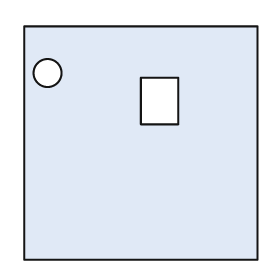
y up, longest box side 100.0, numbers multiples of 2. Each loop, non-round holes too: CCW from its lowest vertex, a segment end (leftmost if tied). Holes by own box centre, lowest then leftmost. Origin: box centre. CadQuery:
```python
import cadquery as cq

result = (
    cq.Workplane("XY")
    .moveTo(-50.0, -50.0)
    .lineTo(50.0, -50.0)
    .lineTo(50.0, 50.0)
    .lineTo(-50.0, 50.0)
    .close()
    .moveTo(0.0, 8.0)
    .lineTo(16.0, 8.0)
    .lineTo(16.0, 28.0)
    .lineTo(0.0, 28.0)
    .close()
    .moveTo(-40.0, 30.0)
    .circle(6.0)
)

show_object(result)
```